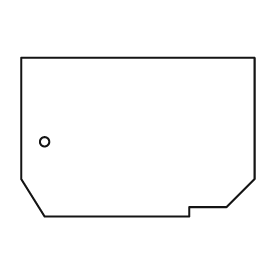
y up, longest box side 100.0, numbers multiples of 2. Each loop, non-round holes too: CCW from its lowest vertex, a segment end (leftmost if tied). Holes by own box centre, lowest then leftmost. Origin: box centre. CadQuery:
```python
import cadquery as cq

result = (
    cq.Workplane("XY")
    .moveTo(-40.0, -34.0)
    .lineTo(22.0, -34.0)
    .lineTo(22.0, -30.0)
    .lineTo(38.0, -30.0)
    .lineTo(50.0, -18.0)
    .lineTo(50.0, 34.0)
    .lineTo(-50.0, 34.0)
    .lineTo(-50.0, -18.0)
    .close()
    .moveTo(-40.0, -2.0)
    .circle(2.0)
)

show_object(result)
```